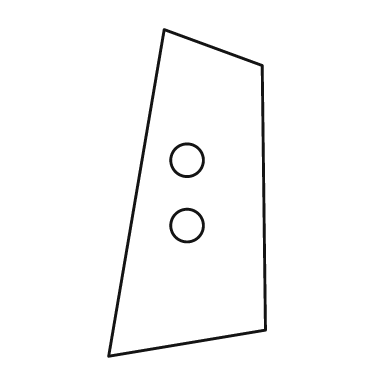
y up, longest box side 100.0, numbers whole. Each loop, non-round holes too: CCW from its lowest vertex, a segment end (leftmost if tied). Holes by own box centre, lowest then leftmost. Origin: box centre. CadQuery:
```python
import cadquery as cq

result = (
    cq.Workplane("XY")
    .moveTo(-24.0, -50.0)
    .lineTo(24.0, -42.0)
    .lineTo(23.0, 39.0)
    .lineTo(-7.0, 50.0)
    .close()
    .moveTo(0.0, -10.0)
    .circle(5.0)
    .moveTo(0.0, 10.0)
    .circle(5.0)
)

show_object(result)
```